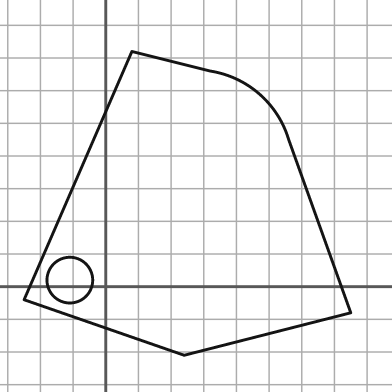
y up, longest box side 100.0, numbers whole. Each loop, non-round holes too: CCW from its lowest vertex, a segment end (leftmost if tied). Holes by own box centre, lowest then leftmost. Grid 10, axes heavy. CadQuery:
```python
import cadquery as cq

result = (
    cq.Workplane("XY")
    .moveTo(24.0, -21.0)
    .lineTo(75.0, -8.0)
    .lineTo(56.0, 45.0)
    .threePointArc((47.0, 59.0), (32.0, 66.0))
    .lineTo(8.0, 72.0)
    .lineTo(-25.0, -4.0)
    .close()
    .moveTo(-11.0, 2.0)
    .circle(7.0)
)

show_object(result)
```